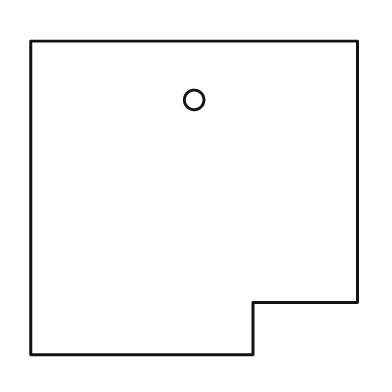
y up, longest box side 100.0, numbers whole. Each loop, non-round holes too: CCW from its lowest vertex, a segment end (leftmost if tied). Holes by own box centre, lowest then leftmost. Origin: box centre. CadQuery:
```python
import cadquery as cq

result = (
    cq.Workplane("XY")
    .moveTo(-50.0, -48.0)
    .lineTo(18.0, -48.0)
    .lineTo(18.0, -32.0)
    .lineTo(50.0, -32.0)
    .lineTo(50.0, 48.0)
    .lineTo(-50.0, 48.0)
    .close()
    .moveTo(0.0, 30.0)
    .circle(3.0)
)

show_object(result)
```